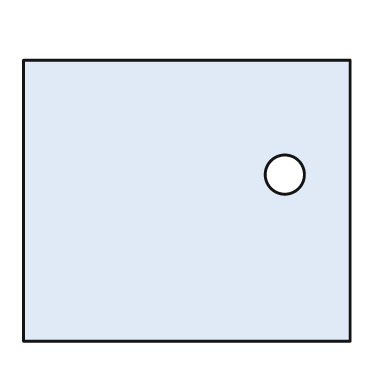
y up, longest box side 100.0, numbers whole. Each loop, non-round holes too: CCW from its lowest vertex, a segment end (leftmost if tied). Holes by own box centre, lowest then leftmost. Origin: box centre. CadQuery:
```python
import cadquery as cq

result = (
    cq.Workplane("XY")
    .moveTo(-50.0, -43.0)
    .lineTo(50.0, -43.0)
    .lineTo(50.0, 43.0)
    .lineTo(-50.0, 43.0)
    .close()
    .moveTo(30.0, 8.0)
    .circle(6.0)
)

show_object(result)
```